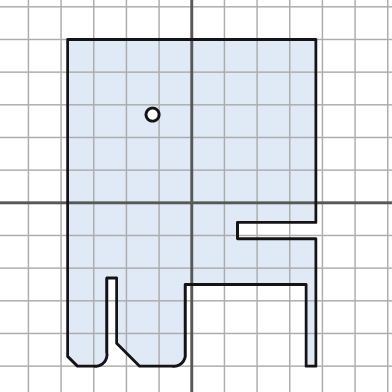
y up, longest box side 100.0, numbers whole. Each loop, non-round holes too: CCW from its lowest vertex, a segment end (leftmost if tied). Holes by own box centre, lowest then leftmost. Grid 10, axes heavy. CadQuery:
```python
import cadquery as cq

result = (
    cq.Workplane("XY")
    .moveTo(-35.0, -50.0)
    .lineTo(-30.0, -50.0)
    .threePointArc((-27.0, -49.0), (-26.0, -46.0))
    .lineTo(-26.0, -23.0)
    .lineTo(-23.0, -23.0)
    .lineTo(-23.0, -43.0)
    .lineTo(-16.0, -50.0)
    .lineTo(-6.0, -50.0)
    .threePointArc((-3.0, -49.0), (-2.0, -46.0))
    .lineTo(-2.0, -25.0)
    .lineTo(35.0, -25.0)
    .lineTo(35.0, -50.0)
    .lineTo(38.0, -50.0)
    .lineTo(38.0, -11.0)
    .lineTo(14.0, -11.0)
    .lineTo(14.0, -6.0)
    .lineTo(38.0, -6.0)
    .lineTo(38.0, 50.0)
    .lineTo(-38.0, 50.0)
    .lineTo(-38.0, -47.0)
    .close()
    .moveTo(-12.0, 27.0)
    .circle(2.0)
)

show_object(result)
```